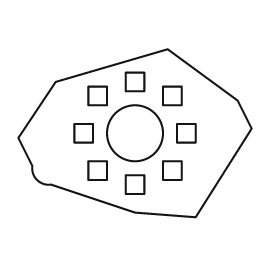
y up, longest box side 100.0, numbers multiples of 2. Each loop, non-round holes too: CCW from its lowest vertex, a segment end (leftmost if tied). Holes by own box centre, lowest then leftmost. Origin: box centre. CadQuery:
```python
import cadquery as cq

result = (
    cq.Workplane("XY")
    .moveTo(26.0, -36.0)
    .lineTo(50.0, 2.0)
    .lineTo(44.0, 14.0)
    .lineTo(14.0, 36.0)
    .lineTo(-34.0, 22.0)
    .lineTo(-50.0, -2.0)
    .lineTo(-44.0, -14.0)
    .threePointArc((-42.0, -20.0), (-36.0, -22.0))
    .lineTo(0.0, -34.0)
    .close()
    .moveTo(-4.0, -26.0)
    .lineTo(4.0, -26.0)
    .lineTo(4.0, -18.0)
    .lineTo(-4.0, -18.0)
    .close()
    .moveTo(-20.0, -20.0)
    .lineTo(-12.0, -20.0)
    .lineTo(-12.0, -12.0)
    .lineTo(-20.0, -12.0)
    .close()
    .moveTo(12.0, -20.0)
    .lineTo(20.0, -20.0)
    .lineTo(20.0, -12.0)
    .lineTo(12.0, -12.0)
    .close()
    .moveTo(-26.0, -4.0)
    .lineTo(-18.0, -4.0)
    .lineTo(-18.0, 4.0)
    .lineTo(-26.0, 4.0)
    .close()
    .moveTo(0.0, 0.0)
    .circle(12.0)
    .moveTo(18.0, -4.0)
    .lineTo(26.0, -4.0)
    .lineTo(26.0, 4.0)
    .lineTo(18.0, 4.0)
    .close()
    .moveTo(-20.0, 12.0)
    .lineTo(-12.0, 12.0)
    .lineTo(-12.0, 20.0)
    .lineTo(-20.0, 20.0)
    .close()
    .moveTo(12.0, 12.0)
    .lineTo(20.0, 12.0)
    .lineTo(20.0, 20.0)
    .lineTo(12.0, 20.0)
    .close()
    .moveTo(-4.0, 18.0)
    .lineTo(4.0, 18.0)
    .lineTo(4.0, 26.0)
    .lineTo(-4.0, 26.0)
    .close()
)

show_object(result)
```